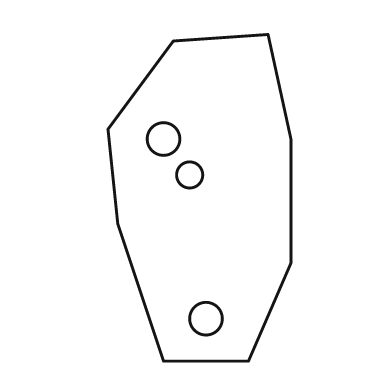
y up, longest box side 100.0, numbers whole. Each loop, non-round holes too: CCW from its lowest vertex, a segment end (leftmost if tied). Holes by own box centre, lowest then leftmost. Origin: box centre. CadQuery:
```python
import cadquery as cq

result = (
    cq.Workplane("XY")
    .moveTo(-11.0, -50.0)
    .lineTo(15.0, -50.0)
    .lineTo(28.0, -20.0)
    .lineTo(28.0, 18.0)
    .lineTo(21.0, 50.0)
    .lineTo(-8.0, 48.0)
    .lineTo(-28.0, 21.0)
    .lineTo(-25.0, -8.0)
    .close()
    .moveTo(2.0, -37.0)
    .circle(5.0)
    .moveTo(-3.0, 7.0)
    .circle(4.0)
    .moveTo(-11.0, 18.0)
    .circle(5.0)
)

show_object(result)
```